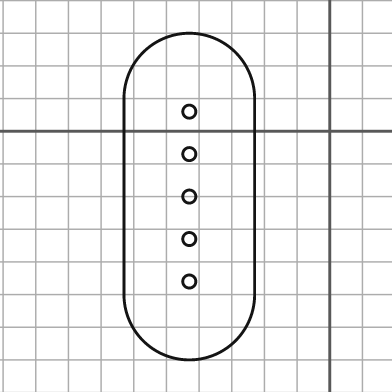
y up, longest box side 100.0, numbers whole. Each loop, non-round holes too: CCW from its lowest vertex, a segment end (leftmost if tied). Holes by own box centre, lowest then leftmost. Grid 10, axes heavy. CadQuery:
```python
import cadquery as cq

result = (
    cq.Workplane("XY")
    .moveTo(-63.0, -50.0)
    .threePointArc((-43.0, -70.0), (-23.0, -50.0))
    .lineTo(-23.0, 10.0)
    .threePointArc((-43.0, 30.0), (-63.0, 10.0))
    .close()
    .moveTo(-43.0, -46.0)
    .circle(2.0)
    .moveTo(-43.0, -33.0)
    .circle(2.0)
    .moveTo(-43.0, -20.0)
    .circle(2.0)
    .moveTo(-43.0, -7.0)
    .circle(2.0)
    .moveTo(-43.0, 6.0)
    .circle(2.0)
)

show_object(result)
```